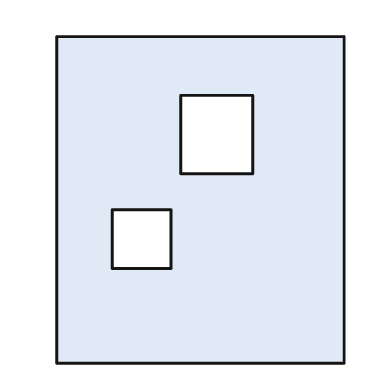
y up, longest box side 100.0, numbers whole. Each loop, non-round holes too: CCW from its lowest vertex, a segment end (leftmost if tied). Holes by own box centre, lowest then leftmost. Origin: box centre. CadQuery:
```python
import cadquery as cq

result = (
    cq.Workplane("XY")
    .moveTo(-44.0, -50.0)
    .lineTo(44.0, -50.0)
    .lineTo(44.0, 50.0)
    .lineTo(-44.0, 50.0)
    .close()
    .moveTo(-27.0, -21.0)
    .lineTo(-9.0, -21.0)
    .lineTo(-9.0, -3.0)
    .lineTo(-27.0, -3.0)
    .close()
    .moveTo(-6.0, 8.0)
    .lineTo(16.0, 8.0)
    .lineTo(16.0, 32.0)
    .lineTo(-6.0, 32.0)
    .close()
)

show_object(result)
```